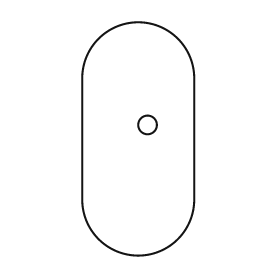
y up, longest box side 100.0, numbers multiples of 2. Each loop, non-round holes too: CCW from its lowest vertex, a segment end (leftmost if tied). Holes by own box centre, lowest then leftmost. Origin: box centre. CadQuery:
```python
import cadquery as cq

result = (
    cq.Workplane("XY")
    .moveTo(-24.0, -26.0)
    .threePointArc((0.0, -50.0), (24.0, -26.0))
    .lineTo(24.0, 26.0)
    .threePointArc((0.0, 50.0), (-24.0, 26.0))
    .close()
    .moveTo(4.0, 6.0)
    .circle(4.0)
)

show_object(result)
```